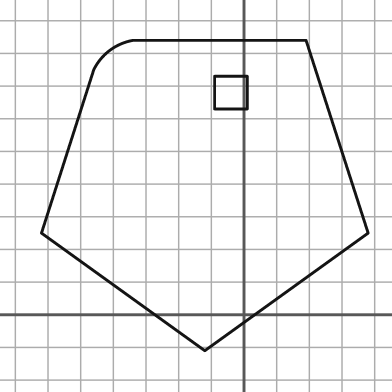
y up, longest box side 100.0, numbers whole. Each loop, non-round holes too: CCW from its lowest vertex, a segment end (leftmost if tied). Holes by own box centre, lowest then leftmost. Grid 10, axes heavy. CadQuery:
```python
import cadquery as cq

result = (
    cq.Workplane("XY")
    .moveTo(-12.0, -11.0)
    .lineTo(38.0, 25.0)
    .lineTo(19.0, 84.0)
    .lineTo(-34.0, 84.0)
    .threePointArc((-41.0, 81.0), (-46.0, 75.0))
    .lineTo(-62.0, 25.0)
    .close()
    .moveTo(-9.0, 63.0)
    .lineTo(1.0, 63.0)
    .lineTo(1.0, 73.0)
    .lineTo(-9.0, 73.0)
    .close()
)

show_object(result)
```